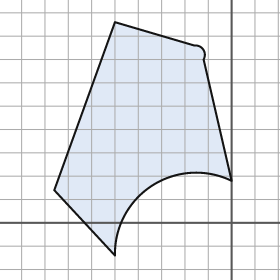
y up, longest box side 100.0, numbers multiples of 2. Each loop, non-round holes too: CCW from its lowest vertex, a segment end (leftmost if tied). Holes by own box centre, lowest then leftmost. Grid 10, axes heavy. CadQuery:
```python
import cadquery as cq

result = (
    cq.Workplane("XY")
    .moveTo(-50.0, -14.0)
    .threePointArc((-34.0, 16.0), (0.0, 18.0))
    .lineTo(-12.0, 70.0)
    .threePointArc((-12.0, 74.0), (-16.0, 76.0))
    .lineTo(-50.0, 86.0)
    .lineTo(-76.0, 14.0)
    .close()
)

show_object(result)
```